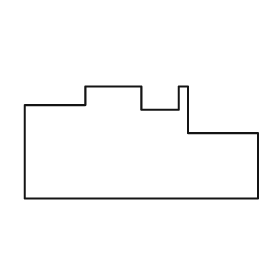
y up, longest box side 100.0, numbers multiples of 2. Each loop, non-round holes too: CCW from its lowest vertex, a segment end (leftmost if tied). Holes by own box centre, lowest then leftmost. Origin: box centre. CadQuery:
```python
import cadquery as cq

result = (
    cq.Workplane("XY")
    .moveTo(-50.0, -24.0)
    .lineTo(50.0, -24.0)
    .lineTo(50.0, 4.0)
    .lineTo(20.0, 4.0)
    .lineTo(20.0, 24.0)
    .lineTo(16.0, 24.0)
    .lineTo(16.0, 14.0)
    .lineTo(0.0, 14.0)
    .lineTo(0.0, 24.0)
    .lineTo(-24.0, 24.0)
    .lineTo(-24.0, 16.0)
    .lineTo(-50.0, 16.0)
    .close()
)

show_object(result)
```